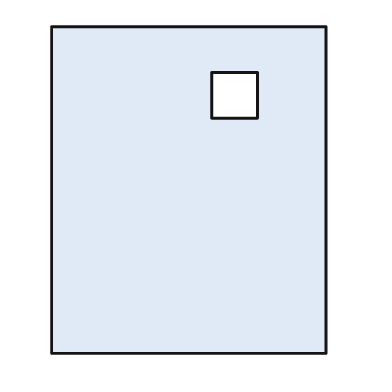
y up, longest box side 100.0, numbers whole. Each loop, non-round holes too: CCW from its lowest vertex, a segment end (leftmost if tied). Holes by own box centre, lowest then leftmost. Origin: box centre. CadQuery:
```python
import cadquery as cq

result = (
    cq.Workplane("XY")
    .moveTo(-42.0, -50.0)
    .lineTo(42.0, -50.0)
    .lineTo(42.0, 50.0)
    .lineTo(-42.0, 50.0)
    .close()
    .moveTo(7.0, 22.0)
    .lineTo(21.0, 22.0)
    .lineTo(21.0, 36.0)
    .lineTo(7.0, 36.0)
    .close()
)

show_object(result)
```